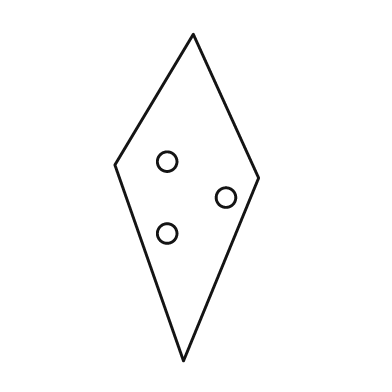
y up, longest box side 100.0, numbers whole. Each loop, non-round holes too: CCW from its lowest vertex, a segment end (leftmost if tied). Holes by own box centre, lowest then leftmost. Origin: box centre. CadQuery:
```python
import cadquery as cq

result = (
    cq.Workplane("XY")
    .moveTo(-1.0, -50.0)
    .lineTo(22.0, 6.0)
    .lineTo(2.0, 50.0)
    .lineTo(-22.0, 10.0)
    .close()
    .moveTo(-6.0, -11.0)
    .circle(3.0)
    .moveTo(12.0, 0.0)
    .circle(3.0)
    .moveTo(-6.0, 11.0)
    .circle(3.0)
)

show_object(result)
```